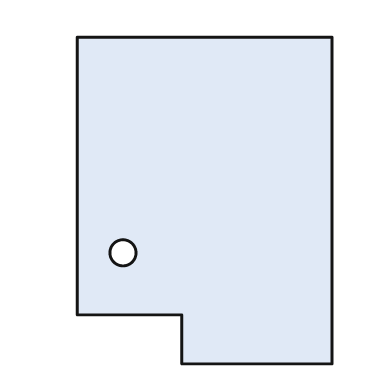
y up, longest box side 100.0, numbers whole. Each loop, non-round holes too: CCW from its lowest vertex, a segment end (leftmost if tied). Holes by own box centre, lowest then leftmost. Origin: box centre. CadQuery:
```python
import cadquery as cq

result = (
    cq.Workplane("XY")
    .moveTo(-7.0, -50.0)
    .lineTo(39.0, -50.0)
    .lineTo(39.0, 50.0)
    .lineTo(-39.0, 50.0)
    .lineTo(-39.0, -35.0)
    .lineTo(-7.0, -35.0)
    .close()
    .moveTo(-25.0, -16.0)
    .circle(4.0)
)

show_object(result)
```